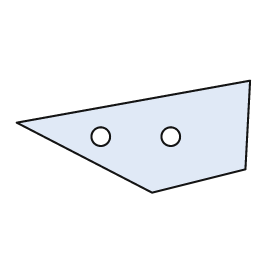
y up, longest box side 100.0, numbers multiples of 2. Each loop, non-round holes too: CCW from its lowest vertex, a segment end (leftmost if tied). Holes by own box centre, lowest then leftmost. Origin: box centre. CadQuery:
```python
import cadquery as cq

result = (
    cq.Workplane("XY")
    .moveTo(8.0, -24.0)
    .lineTo(48.0, -14.0)
    .lineTo(50.0, 24.0)
    .lineTo(-50.0, 6.0)
    .close()
    .moveTo(-14.0, 0.0)
    .circle(4.0)
    .moveTo(16.0, 0.0)
    .circle(4.0)
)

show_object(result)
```